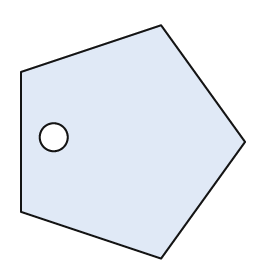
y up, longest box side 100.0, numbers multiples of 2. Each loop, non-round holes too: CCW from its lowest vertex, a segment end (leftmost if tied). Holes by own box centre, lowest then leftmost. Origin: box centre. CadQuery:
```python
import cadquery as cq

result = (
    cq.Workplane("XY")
    .moveTo(12.0, -50.0)
    .lineTo(48.0, 0.0)
    .lineTo(12.0, 50.0)
    .lineTo(-48.0, 30.0)
    .lineTo(-48.0, -30.0)
    .close()
    .moveTo(-34.0, 2.0)
    .circle(6.0)
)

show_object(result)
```